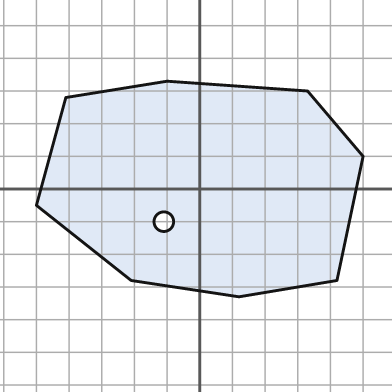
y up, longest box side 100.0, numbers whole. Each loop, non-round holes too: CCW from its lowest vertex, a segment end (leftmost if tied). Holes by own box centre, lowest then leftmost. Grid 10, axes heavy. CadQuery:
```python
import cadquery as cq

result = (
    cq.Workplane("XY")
    .moveTo(12.0, -33.0)
    .lineTo(42.0, -28.0)
    .lineTo(50.0, 10.0)
    .lineTo(33.0, 30.0)
    .lineTo(-10.0, 33.0)
    .lineTo(-41.0, 28.0)
    .lineTo(-50.0, -5.0)
    .lineTo(-21.0, -28.0)
    .close()
    .moveTo(-11.0, -10.0)
    .circle(3.0)
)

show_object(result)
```